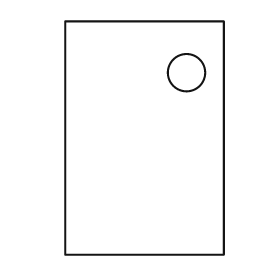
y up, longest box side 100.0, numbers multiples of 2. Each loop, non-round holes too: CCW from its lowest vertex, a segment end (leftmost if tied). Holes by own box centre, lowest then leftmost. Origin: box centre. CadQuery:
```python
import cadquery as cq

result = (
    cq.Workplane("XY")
    .moveTo(-34.0, -50.0)
    .lineTo(34.0, -50.0)
    .lineTo(34.0, 50.0)
    .lineTo(-34.0, 50.0)
    .close()
    .moveTo(18.0, 28.0)
    .circle(8.0)
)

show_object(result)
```